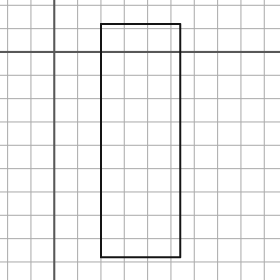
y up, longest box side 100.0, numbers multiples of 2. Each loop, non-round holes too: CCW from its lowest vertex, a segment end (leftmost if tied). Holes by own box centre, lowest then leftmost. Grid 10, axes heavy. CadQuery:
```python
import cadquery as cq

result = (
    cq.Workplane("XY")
    .moveTo(20.0, -88.0)
    .lineTo(54.0, -88.0)
    .lineTo(54.0, 12.0)
    .lineTo(20.0, 12.0)
    .close()
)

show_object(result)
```